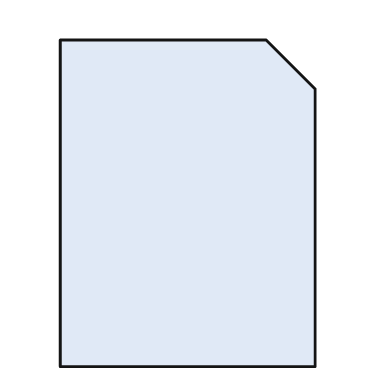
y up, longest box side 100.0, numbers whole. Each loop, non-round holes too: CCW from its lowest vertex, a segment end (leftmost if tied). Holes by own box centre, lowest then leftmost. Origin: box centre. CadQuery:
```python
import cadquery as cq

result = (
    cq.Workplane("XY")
    .moveTo(-39.0, -50.0)
    .lineTo(39.0, -50.0)
    .lineTo(39.0, 35.0)
    .lineTo(24.0, 50.0)
    .lineTo(-39.0, 50.0)
    .close()
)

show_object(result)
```